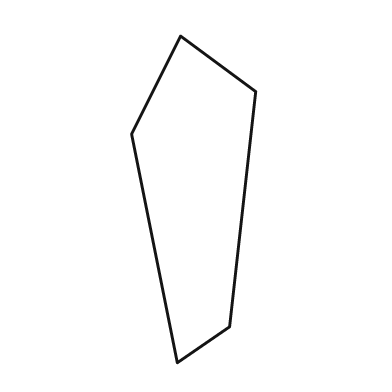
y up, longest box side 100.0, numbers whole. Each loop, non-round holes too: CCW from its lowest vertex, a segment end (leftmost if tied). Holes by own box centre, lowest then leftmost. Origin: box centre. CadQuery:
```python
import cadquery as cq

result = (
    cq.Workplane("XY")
    .moveTo(-5.0, -50.0)
    .lineTo(11.0, -39.0)
    .lineTo(19.0, 33.0)
    .lineTo(-4.0, 50.0)
    .lineTo(-19.0, 20.0)
    .close()
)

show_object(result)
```